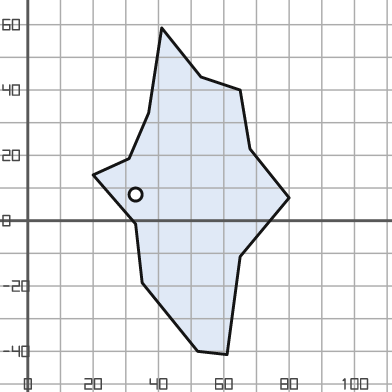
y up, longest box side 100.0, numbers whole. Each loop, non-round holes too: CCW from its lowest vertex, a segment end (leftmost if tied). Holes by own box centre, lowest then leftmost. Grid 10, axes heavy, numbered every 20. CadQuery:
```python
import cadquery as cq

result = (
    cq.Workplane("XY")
    .moveTo(61.0, -41.0)
    .lineTo(65.0, -11.0)
    .lineTo(80.0, 7.0)
    .lineTo(68.0, 22.0)
    .lineTo(65.0, 40.0)
    .lineTo(53.0, 44.0)
    .lineTo(41.0, 59.0)
    .lineTo(37.0, 33.0)
    .lineTo(31.0, 19.0)
    .lineTo(20.0, 14.0)
    .lineTo(33.0, -1.0)
    .lineTo(35.0, -19.0)
    .lineTo(52.0, -40.0)
    .close()
    .moveTo(33.0, 8.0)
    .circle(2.0)
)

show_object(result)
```